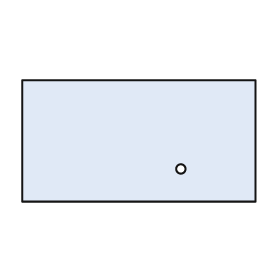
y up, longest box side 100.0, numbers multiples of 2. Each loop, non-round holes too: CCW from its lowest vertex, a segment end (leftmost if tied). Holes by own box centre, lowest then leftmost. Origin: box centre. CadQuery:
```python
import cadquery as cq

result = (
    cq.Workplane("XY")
    .moveTo(-50.0, -26.0)
    .lineTo(50.0, -26.0)
    .lineTo(50.0, 26.0)
    .lineTo(-50.0, 26.0)
    .close()
    .moveTo(18.0, -12.0)
    .circle(2.0)
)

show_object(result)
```